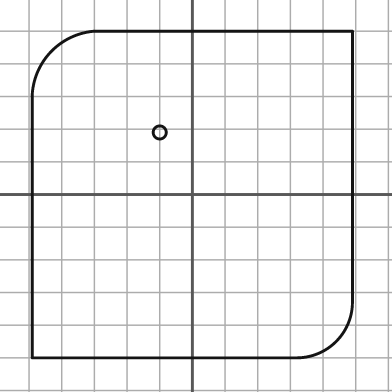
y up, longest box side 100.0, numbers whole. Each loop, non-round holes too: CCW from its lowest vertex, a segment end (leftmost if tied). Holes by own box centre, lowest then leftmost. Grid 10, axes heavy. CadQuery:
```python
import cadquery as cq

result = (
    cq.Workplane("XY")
    .moveTo(-49.0, -50.0)
    .lineTo(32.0, -50.0)
    .threePointArc((44.0, -45.0), (49.0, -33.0))
    .lineTo(49.0, 50.0)
    .lineTo(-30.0, 50.0)
    .threePointArc((-43.0, 44.0), (-49.0, 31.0))
    .close()
    .moveTo(-10.0, 19.0)
    .circle(2.0)
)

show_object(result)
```